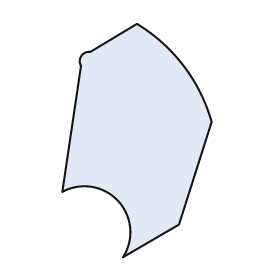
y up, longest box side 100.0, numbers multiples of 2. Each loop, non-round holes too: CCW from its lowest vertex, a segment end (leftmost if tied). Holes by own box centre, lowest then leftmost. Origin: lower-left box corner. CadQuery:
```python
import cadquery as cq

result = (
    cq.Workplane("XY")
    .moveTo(26.0, 0.0)
    .lineTo(50.0, 14.0)
    .lineTo(64.0, 58.0)
    .threePointArc((52.0, 82.0), (32.0, 100.0))
    .lineTo(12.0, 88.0)
    .threePointArc((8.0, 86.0), (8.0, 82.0))
    .lineTo(0.0, 28.0)
    .threePointArc((24.0, 24.0), (26.0, 0.0))
    .close()
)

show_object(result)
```